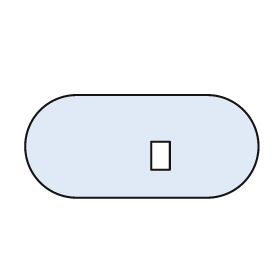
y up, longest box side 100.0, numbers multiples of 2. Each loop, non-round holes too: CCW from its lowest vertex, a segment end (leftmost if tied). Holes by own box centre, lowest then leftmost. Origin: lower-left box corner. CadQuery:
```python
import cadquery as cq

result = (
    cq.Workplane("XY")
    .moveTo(22.0, 0.0)
    .lineTo(78.0, 0.0)
    .threePointArc((100.0, 22.0), (78.0, 44.0))
    .lineTo(22.0, 44.0)
    .threePointArc((0.0, 22.0), (22.0, 0.0))
    .close()
    .moveTo(54.0, 12.0)
    .lineTo(62.0, 12.0)
    .lineTo(62.0, 24.0)
    .lineTo(54.0, 24.0)
    .close()
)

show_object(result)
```